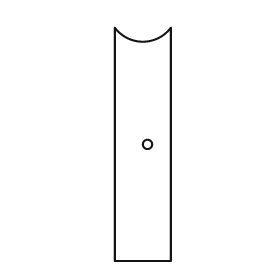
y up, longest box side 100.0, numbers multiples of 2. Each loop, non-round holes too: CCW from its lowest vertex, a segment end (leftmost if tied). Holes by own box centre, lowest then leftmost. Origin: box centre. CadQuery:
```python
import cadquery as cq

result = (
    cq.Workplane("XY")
    .moveTo(-12.0, -50.0)
    .lineTo(12.0, -50.0)
    .lineTo(12.0, 50.0)
    .threePointArc((0.0, 44.0), (-12.0, 50.0))
    .close()
    .moveTo(2.0, 0.0)
    .circle(2.0)
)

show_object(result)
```